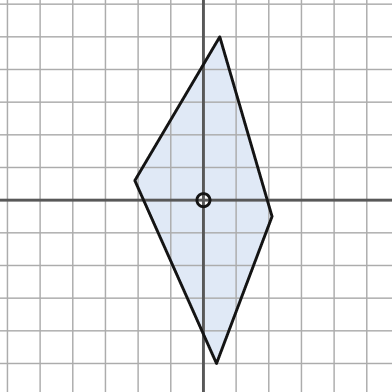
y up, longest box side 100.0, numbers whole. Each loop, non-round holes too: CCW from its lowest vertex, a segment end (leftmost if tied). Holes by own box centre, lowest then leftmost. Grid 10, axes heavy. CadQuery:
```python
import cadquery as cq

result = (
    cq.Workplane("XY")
    .moveTo(4.0, -50.0)
    .lineTo(21.0, -5.0)
    .lineTo(5.0, 50.0)
    .lineTo(-21.0, 6.0)
    .close()
    .moveTo(0.0, 0.0)
    .circle(2.0)
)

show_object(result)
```